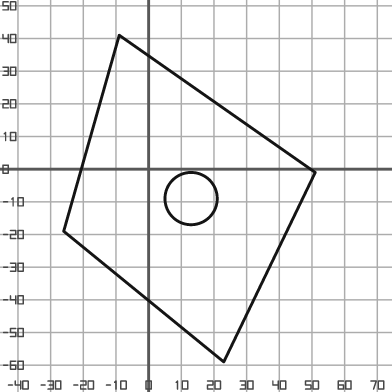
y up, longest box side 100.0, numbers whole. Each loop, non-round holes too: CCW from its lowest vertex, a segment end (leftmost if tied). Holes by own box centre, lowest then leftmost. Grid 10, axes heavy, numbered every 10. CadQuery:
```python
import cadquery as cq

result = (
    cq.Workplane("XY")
    .moveTo(23.0, -59.0)
    .lineTo(51.0, -1.0)
    .lineTo(-9.0, 41.0)
    .lineTo(-26.0, -19.0)
    .close()
    .moveTo(13.0, -9.0)
    .circle(8.0)
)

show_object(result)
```